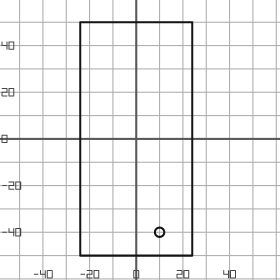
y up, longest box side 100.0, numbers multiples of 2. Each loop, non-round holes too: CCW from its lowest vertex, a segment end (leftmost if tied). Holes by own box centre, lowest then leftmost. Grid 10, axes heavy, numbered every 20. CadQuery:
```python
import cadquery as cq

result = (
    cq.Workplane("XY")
    .moveTo(-24.0, -50.0)
    .lineTo(24.0, -50.0)
    .lineTo(24.0, 50.0)
    .lineTo(-24.0, 50.0)
    .close()
    .moveTo(10.0, -40.0)
    .circle(2.0)
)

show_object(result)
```